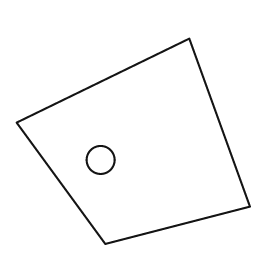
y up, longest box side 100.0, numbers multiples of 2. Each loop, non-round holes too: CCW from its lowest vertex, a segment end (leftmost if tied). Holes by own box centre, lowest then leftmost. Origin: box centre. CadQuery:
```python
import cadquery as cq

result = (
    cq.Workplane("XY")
    .moveTo(-12.0, -44.0)
    .lineTo(50.0, -28.0)
    .lineTo(24.0, 44.0)
    .lineTo(-50.0, 8.0)
    .close()
    .moveTo(-14.0, -8.0)
    .circle(6.0)
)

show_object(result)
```